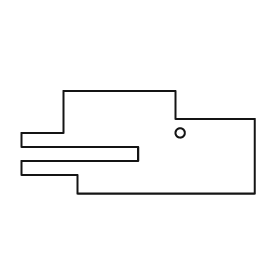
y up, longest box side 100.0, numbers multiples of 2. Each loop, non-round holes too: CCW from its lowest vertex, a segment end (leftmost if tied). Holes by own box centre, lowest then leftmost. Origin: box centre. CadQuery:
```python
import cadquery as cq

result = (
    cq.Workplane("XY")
    .moveTo(-26.0, -22.0)
    .lineTo(50.0, -22.0)
    .lineTo(50.0, 10.0)
    .lineTo(16.0, 10.0)
    .lineTo(16.0, 22.0)
    .lineTo(-32.0, 22.0)
    .lineTo(-32.0, 4.0)
    .lineTo(-50.0, 4.0)
    .lineTo(-50.0, -2.0)
    .lineTo(0.0, -2.0)
    .lineTo(0.0, -8.0)
    .lineTo(-50.0, -8.0)
    .lineTo(-50.0, -14.0)
    .lineTo(-26.0, -14.0)
    .close()
    .moveTo(18.0, 4.0)
    .circle(2.0)
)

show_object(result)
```